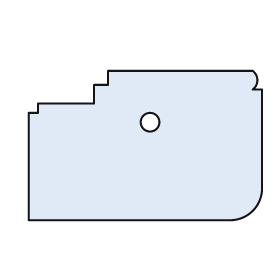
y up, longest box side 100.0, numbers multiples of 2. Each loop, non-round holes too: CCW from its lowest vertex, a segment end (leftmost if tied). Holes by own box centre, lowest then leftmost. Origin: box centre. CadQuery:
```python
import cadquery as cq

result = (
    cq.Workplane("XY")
    .moveTo(-50.0, -32.0)
    .lineTo(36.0, -32.0)
    .threePointArc((46.0, -28.0), (50.0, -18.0))
    .lineTo(50.0, 24.0)
    .lineTo(46.0, 24.0)
    .threePointArc((48.0, 28.0), (46.0, 32.0))
    .lineTo(-16.0, 32.0)
    .lineTo(-16.0, 26.0)
    .lineTo(-22.0, 26.0)
    .lineTo(-22.0, 18.0)
    .lineTo(-46.0, 18.0)
    .lineTo(-46.0, 14.0)
    .lineTo(-50.0, 14.0)
    .close()
    .moveTo(2.0, 10.0)
    .circle(4.0)
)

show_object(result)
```